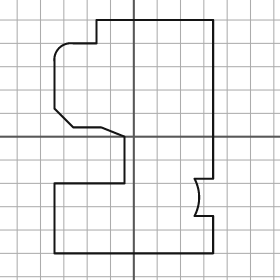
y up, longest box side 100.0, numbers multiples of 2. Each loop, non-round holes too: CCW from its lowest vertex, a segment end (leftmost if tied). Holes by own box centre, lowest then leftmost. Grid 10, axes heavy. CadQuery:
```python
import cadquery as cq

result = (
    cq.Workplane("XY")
    .moveTo(-34.0, -50.0)
    .lineTo(34.0, -50.0)
    .lineTo(34.0, -34.0)
    .lineTo(26.0, -34.0)
    .threePointArc((28.0, -26.0), (26.0, -18.0))
    .lineTo(34.0, -18.0)
    .lineTo(34.0, 50.0)
    .lineTo(-16.0, 50.0)
    .lineTo(-16.0, 40.0)
    .lineTo(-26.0, 40.0)
    .threePointArc((-32.0, 38.0), (-34.0, 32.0))
    .lineTo(-34.0, 12.0)
    .lineTo(-26.0, 4.0)
    .lineTo(-14.0, 4.0)
    .lineTo(-4.0, 0.0)
    .lineTo(-4.0, -20.0)
    .lineTo(-34.0, -20.0)
    .close()
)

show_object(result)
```